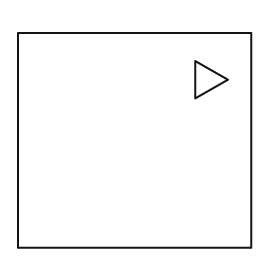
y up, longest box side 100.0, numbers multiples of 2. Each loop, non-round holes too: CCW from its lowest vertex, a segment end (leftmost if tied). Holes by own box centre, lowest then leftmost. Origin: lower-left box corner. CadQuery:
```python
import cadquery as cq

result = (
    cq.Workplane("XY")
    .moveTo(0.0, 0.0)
    .lineTo(100.0, 0.0)
    .lineTo(100.0, 92.0)
    .lineTo(0.0, 92.0)
    .close()
    .moveTo(76.0, 64.0)
    .lineTo(90.0, 72.0)
    .lineTo(76.0, 80.0)
    .close()
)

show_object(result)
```